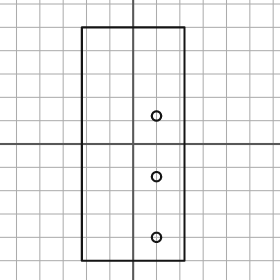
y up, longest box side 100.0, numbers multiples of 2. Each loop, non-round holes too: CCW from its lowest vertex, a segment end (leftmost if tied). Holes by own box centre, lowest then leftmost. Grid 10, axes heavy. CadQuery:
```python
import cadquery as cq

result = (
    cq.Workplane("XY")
    .moveTo(-22.0, -50.0)
    .lineTo(22.0, -50.0)
    .lineTo(22.0, 50.0)
    .lineTo(-22.0, 50.0)
    .close()
    .moveTo(10.0, -40.0)
    .circle(2.0)
    .moveTo(10.0, -14.0)
    .circle(2.0)
    .moveTo(10.0, 12.0)
    .circle(2.0)
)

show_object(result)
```